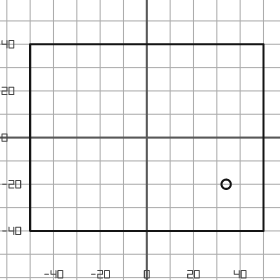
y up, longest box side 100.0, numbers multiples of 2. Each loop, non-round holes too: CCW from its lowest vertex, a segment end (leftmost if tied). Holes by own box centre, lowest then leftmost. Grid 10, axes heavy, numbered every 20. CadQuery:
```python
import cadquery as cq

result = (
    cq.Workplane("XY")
    .moveTo(-50.0, -40.0)
    .lineTo(50.0, -40.0)
    .lineTo(50.0, 40.0)
    .lineTo(-50.0, 40.0)
    .close()
    .moveTo(34.0, -20.0)
    .circle(2.0)
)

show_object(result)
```